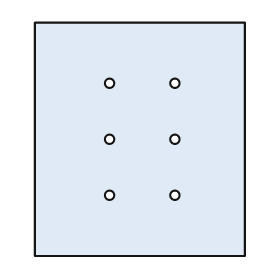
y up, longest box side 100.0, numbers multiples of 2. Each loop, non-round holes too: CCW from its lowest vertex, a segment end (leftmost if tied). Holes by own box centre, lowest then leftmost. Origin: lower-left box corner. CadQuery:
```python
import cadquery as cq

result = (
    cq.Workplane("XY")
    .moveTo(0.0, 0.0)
    .lineTo(90.0, 0.0)
    .lineTo(90.0, 100.0)
    .lineTo(0.0, 100.0)
    .close()
    .moveTo(32.0, 26.0)
    .circle(2.0)
    .moveTo(60.0, 26.0)
    .circle(2.0)
    .moveTo(32.0, 50.0)
    .circle(2.0)
    .moveTo(60.0, 50.0)
    .circle(2.0)
    .moveTo(32.0, 74.0)
    .circle(2.0)
    .moveTo(60.0, 74.0)
    .circle(2.0)
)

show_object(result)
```